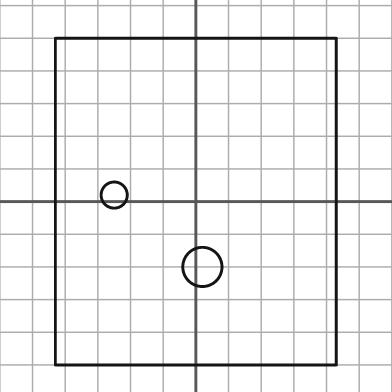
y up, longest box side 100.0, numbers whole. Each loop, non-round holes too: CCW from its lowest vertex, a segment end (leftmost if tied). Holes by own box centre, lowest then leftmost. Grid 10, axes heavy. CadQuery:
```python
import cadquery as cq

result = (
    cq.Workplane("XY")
    .moveTo(-43.0, -50.0)
    .lineTo(43.0, -50.0)
    .lineTo(43.0, 50.0)
    .lineTo(-43.0, 50.0)
    .close()
    .moveTo(2.0, -20.0)
    .circle(6.0)
    .moveTo(-25.0, 2.0)
    .circle(4.0)
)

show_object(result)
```